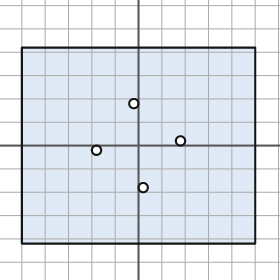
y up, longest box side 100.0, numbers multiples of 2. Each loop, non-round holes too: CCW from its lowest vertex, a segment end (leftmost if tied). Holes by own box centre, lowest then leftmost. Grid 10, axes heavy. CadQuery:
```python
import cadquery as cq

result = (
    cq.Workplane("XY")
    .moveTo(-50.0, -42.0)
    .lineTo(50.0, -42.0)
    .lineTo(50.0, 42.0)
    .lineTo(-50.0, 42.0)
    .close()
    .moveTo(2.0, -18.0)
    .circle(2.0)
    .moveTo(-18.0, -2.0)
    .circle(2.0)
    .moveTo(18.0, 2.0)
    .circle(2.0)
    .moveTo(-2.0, 18.0)
    .circle(2.0)
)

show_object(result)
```